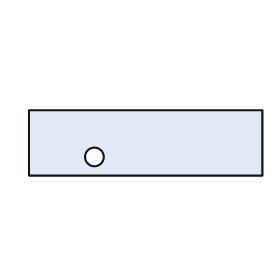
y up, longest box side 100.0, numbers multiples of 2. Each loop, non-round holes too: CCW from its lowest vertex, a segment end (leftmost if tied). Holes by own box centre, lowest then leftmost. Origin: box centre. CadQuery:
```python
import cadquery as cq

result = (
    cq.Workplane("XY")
    .moveTo(-50.0, -14.0)
    .lineTo(50.0, -14.0)
    .lineTo(50.0, 14.0)
    .lineTo(-50.0, 14.0)
    .close()
    .moveTo(-22.0, -6.0)
    .circle(4.0)
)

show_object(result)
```